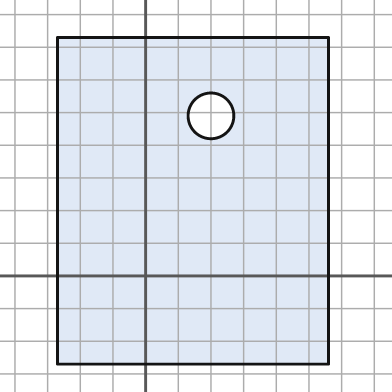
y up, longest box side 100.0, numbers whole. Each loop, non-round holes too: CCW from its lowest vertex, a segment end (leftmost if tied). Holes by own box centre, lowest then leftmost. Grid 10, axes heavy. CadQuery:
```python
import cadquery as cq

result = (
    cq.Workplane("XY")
    .moveTo(-27.0, -27.0)
    .lineTo(56.0, -27.0)
    .lineTo(56.0, 73.0)
    .lineTo(-27.0, 73.0)
    .close()
    .moveTo(20.0, 49.0)
    .circle(7.0)
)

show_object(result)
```